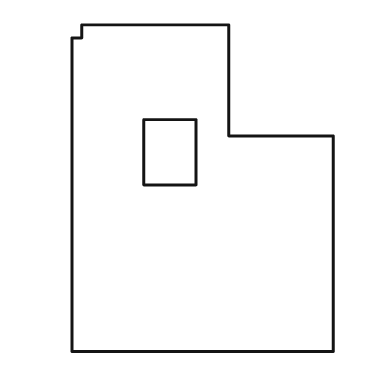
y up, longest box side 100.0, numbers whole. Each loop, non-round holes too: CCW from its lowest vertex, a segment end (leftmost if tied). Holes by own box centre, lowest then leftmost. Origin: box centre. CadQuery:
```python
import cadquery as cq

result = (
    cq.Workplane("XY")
    .moveTo(-40.0, -50.0)
    .lineTo(40.0, -50.0)
    .lineTo(40.0, 16.0)
    .lineTo(8.0, 16.0)
    .lineTo(8.0, 50.0)
    .lineTo(-37.0, 50.0)
    .lineTo(-37.0, 46.0)
    .lineTo(-40.0, 46.0)
    .close()
    .moveTo(-18.0, 1.0)
    .lineTo(-2.0, 1.0)
    .lineTo(-2.0, 21.0)
    .lineTo(-18.0, 21.0)
    .close()
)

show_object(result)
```